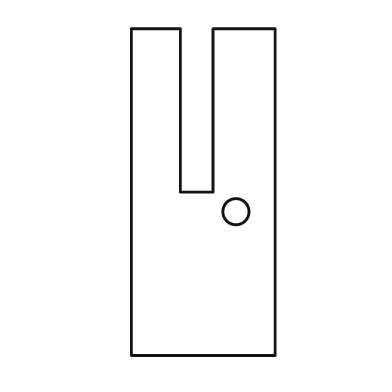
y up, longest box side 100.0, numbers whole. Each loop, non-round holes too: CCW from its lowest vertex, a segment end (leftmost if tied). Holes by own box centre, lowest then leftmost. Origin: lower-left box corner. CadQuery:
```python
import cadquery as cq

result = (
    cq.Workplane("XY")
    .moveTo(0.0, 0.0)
    .lineTo(44.0, 0.0)
    .lineTo(44.0, 100.0)
    .lineTo(25.0, 100.0)
    .lineTo(25.0, 50.0)
    .lineTo(15.0, 50.0)
    .lineTo(15.0, 100.0)
    .lineTo(0.0, 100.0)
    .close()
    .moveTo(32.0, 44.0)
    .circle(4.0)
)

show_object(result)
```